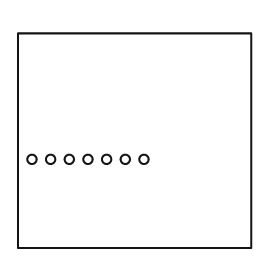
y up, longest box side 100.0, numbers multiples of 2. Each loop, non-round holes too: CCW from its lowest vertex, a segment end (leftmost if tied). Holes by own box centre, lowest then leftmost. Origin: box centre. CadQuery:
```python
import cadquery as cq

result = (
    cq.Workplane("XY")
    .moveTo(-50.0, -46.0)
    .lineTo(50.0, -46.0)
    .lineTo(50.0, 46.0)
    .lineTo(-50.0, 46.0)
    .close()
    .moveTo(-44.0, -8.0)
    .circle(2.0)
    .moveTo(-36.0, -8.0)
    .circle(2.0)
    .moveTo(-28.0, -8.0)
    .circle(2.0)
    .moveTo(-20.0, -8.0)
    .circle(2.0)
    .moveTo(-12.0, -8.0)
    .circle(2.0)
    .moveTo(-4.0, -8.0)
    .circle(2.0)
    .moveTo(4.0, -8.0)
    .circle(2.0)
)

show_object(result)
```